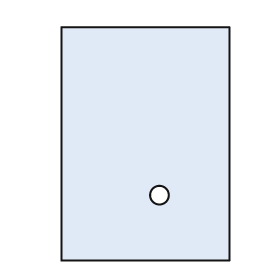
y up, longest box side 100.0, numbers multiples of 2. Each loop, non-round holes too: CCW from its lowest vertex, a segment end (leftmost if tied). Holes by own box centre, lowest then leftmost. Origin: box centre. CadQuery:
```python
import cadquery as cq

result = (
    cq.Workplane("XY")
    .moveTo(-36.0, -50.0)
    .lineTo(36.0, -50.0)
    .lineTo(36.0, 50.0)
    .lineTo(-36.0, 50.0)
    .close()
    .moveTo(6.0, -22.0)
    .circle(4.0)
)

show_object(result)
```